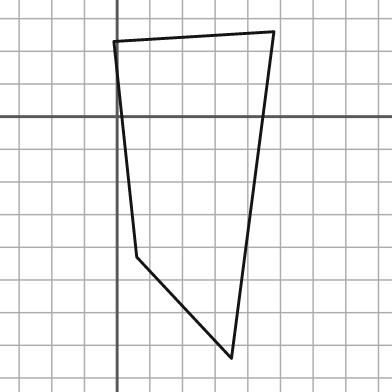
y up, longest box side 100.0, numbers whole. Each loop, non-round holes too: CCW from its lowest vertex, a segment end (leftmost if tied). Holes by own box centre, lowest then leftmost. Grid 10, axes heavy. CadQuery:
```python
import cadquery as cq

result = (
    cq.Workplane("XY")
    .moveTo(35.0, -74.0)
    .lineTo(48.0, 26.0)
    .lineTo(-1.0, 23.0)
    .lineTo(6.0, -43.0)
    .close()
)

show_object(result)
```